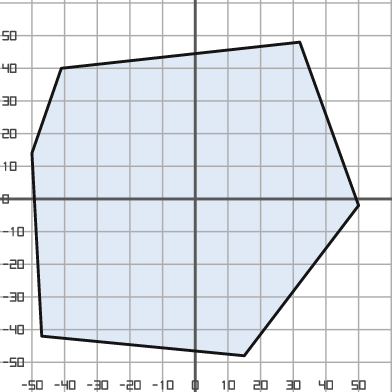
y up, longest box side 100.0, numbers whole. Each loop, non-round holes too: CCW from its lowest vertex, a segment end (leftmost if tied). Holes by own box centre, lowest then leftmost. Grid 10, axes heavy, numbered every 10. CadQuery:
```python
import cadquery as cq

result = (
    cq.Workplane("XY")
    .moveTo(15.0, -48.0)
    .lineTo(50.0, -2.0)
    .lineTo(32.0, 48.0)
    .lineTo(-41.0, 40.0)
    .lineTo(-50.0, 14.0)
    .lineTo(-47.0, -42.0)
    .close()
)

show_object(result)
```